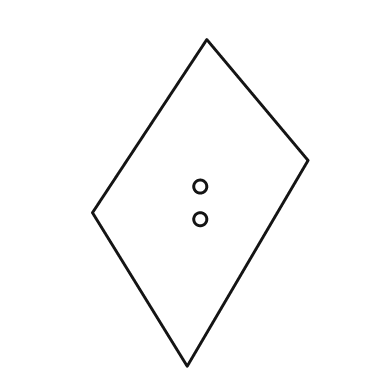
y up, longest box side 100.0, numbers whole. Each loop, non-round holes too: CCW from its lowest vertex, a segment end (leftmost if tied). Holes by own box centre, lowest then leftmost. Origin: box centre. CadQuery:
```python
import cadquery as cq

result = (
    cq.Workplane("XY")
    .moveTo(-4.0, -50.0)
    .lineTo(33.0, 13.0)
    .lineTo(2.0, 50.0)
    .lineTo(-33.0, -3.0)
    .close()
    .moveTo(0.0, -5.0)
    .circle(2.0)
    .moveTo(0.0, 5.0)
    .circle(2.0)
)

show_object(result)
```